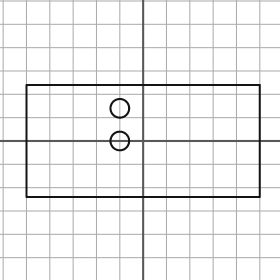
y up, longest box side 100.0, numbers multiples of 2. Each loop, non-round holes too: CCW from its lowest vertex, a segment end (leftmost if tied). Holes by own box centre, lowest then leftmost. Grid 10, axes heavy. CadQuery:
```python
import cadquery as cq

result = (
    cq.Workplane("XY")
    .moveTo(-50.0, -24.0)
    .lineTo(50.0, -24.0)
    .lineTo(50.0, 24.0)
    .lineTo(-50.0, 24.0)
    .close()
    .moveTo(-10.0, 0.0)
    .circle(4.0)
    .moveTo(-10.0, 14.0)
    .circle(4.0)
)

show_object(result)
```